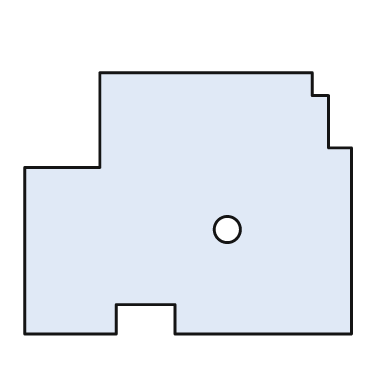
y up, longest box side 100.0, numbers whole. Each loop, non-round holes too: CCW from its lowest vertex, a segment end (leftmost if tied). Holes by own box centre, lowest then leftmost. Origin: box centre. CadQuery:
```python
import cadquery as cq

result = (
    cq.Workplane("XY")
    .moveTo(-50.0, -40.0)
    .lineTo(-22.0, -40.0)
    .lineTo(-22.0, -31.0)
    .lineTo(-4.0, -31.0)
    .lineTo(-4.0, -40.0)
    .lineTo(50.0, -40.0)
    .lineTo(50.0, 17.0)
    .lineTo(43.0, 17.0)
    .lineTo(43.0, 33.0)
    .lineTo(38.0, 33.0)
    .lineTo(38.0, 40.0)
    .lineTo(-27.0, 40.0)
    .lineTo(-27.0, 11.0)
    .lineTo(-50.0, 11.0)
    .close()
    .moveTo(12.0, -8.0)
    .circle(4.0)
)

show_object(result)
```